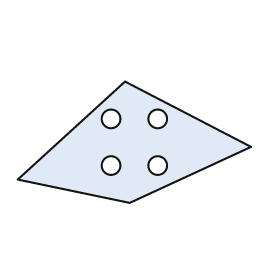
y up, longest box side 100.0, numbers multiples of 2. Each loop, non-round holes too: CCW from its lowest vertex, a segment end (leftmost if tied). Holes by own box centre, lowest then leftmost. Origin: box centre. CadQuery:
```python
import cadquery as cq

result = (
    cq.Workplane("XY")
    .moveTo(-2.0, -26.0)
    .lineTo(50.0, -2.0)
    .lineTo(-4.0, 26.0)
    .lineTo(-50.0, -16.0)
    .close()
    .moveTo(-10.0, -10.0)
    .circle(4.0)
    .moveTo(10.0, -10.0)
    .circle(4.0)
    .moveTo(-10.0, 10.0)
    .circle(4.0)
    .moveTo(10.0, 10.0)
    .circle(4.0)
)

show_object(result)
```